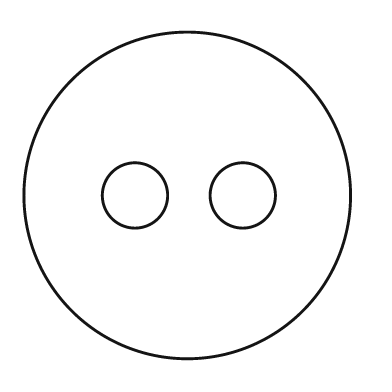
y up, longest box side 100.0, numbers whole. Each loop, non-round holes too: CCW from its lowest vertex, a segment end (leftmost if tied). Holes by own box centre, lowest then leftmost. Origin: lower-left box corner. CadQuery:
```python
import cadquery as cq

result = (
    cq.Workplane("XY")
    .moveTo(50.0, 50.0)
    .circle(50.0)
    .moveTo(34.0, 50.0)
    .circle(10.0)
    .moveTo(67.0, 50.0)
    .circle(10.0)
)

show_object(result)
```